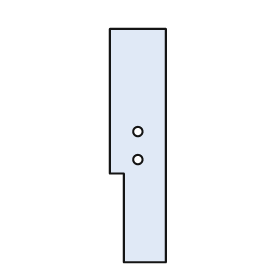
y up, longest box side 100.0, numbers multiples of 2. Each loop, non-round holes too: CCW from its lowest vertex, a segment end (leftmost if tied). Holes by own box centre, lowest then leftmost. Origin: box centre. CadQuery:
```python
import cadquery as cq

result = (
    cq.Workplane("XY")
    .moveTo(-6.0, -50.0)
    .lineTo(12.0, -50.0)
    .lineTo(12.0, 50.0)
    .lineTo(-12.0, 50.0)
    .lineTo(-12.0, -12.0)
    .lineTo(-6.0, -12.0)
    .close()
    .moveTo(0.0, -6.0)
    .circle(2.0)
    .moveTo(0.0, 6.0)
    .circle(2.0)
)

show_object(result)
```